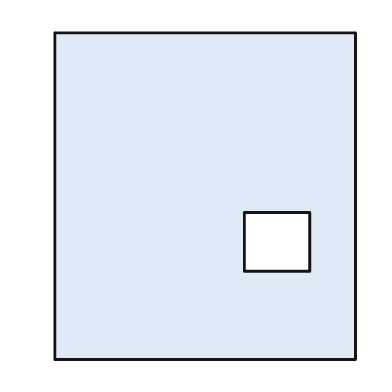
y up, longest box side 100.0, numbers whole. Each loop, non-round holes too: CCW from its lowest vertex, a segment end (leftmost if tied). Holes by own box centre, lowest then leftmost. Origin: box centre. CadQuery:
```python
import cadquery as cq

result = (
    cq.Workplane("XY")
    .moveTo(-46.0, -50.0)
    .lineTo(46.0, -50.0)
    .lineTo(46.0, 50.0)
    .lineTo(-46.0, 50.0)
    .close()
    .moveTo(12.0, -23.0)
    .lineTo(32.0, -23.0)
    .lineTo(32.0, -5.0)
    .lineTo(12.0, -5.0)
    .close()
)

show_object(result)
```